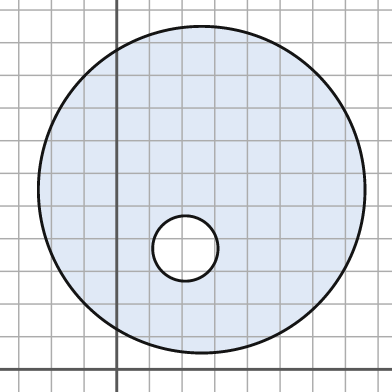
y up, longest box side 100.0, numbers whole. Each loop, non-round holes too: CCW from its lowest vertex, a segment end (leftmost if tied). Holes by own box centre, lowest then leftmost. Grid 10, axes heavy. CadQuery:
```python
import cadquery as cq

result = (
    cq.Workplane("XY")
    .moveTo(26.0, 55.0)
    .circle(50.0)
    .moveTo(21.0, 37.0)
    .circle(10.0)
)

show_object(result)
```